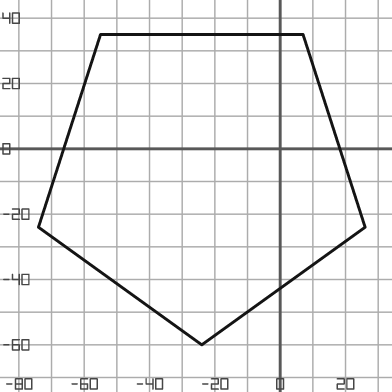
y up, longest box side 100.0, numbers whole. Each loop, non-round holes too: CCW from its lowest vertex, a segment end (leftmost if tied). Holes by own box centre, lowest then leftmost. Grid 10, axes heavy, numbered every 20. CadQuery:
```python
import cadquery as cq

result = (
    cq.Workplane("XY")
    .moveTo(-24.0, -60.0)
    .lineTo(26.0, -24.0)
    .lineTo(7.0, 35.0)
    .lineTo(-55.0, 35.0)
    .lineTo(-74.0, -24.0)
    .close()
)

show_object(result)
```